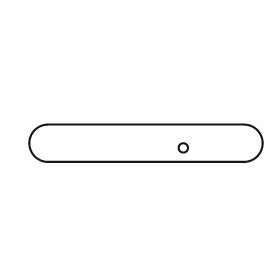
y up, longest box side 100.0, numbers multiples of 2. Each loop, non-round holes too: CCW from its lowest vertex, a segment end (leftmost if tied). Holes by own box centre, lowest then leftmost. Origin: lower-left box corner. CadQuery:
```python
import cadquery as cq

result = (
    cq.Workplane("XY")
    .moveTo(8.0, 0.0)
    .lineTo(92.0, 0.0)
    .threePointArc((100.0, 8.0), (92.0, 16.0))
    .lineTo(8.0, 16.0)
    .threePointArc((0.0, 8.0), (8.0, 0.0))
    .close()
    .moveTo(66.0, 6.0)
    .circle(2.0)
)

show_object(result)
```